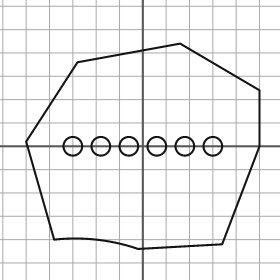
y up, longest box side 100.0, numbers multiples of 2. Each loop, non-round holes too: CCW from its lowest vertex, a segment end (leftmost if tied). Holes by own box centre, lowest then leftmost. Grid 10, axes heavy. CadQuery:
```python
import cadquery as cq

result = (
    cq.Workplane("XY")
    .moveTo(-2.0, -44.0)
    .lineTo(34.0, -42.0)
    .lineTo(50.0, 0.0)
    .lineTo(50.0, 24.0)
    .lineTo(16.0, 44.0)
    .lineTo(-28.0, 36.0)
    .lineTo(-50.0, 2.0)
    .lineTo(-38.0, -40.0)
    .threePointArc((-20.0, -40.0), (-2.0, -44.0))
    .close()
    .moveTo(-30.0, 0.0)
    .circle(4.0)
    .moveTo(-18.0, 0.0)
    .circle(4.0)
    .moveTo(-6.0, 0.0)
    .circle(4.0)
    .moveTo(6.0, 0.0)
    .circle(4.0)
    .moveTo(18.0, 0.0)
    .circle(4.0)
    .moveTo(30.0, 0.0)
    .circle(4.0)
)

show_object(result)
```